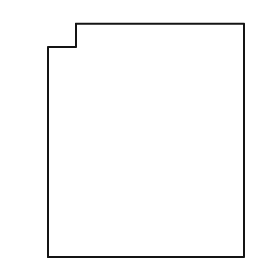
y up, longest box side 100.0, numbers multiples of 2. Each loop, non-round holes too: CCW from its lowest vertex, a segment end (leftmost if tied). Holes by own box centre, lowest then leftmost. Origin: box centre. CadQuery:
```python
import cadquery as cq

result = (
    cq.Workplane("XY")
    .moveTo(-42.0, -50.0)
    .lineTo(42.0, -50.0)
    .lineTo(42.0, 50.0)
    .lineTo(-30.0, 50.0)
    .lineTo(-30.0, 40.0)
    .lineTo(-42.0, 40.0)
    .close()
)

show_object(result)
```